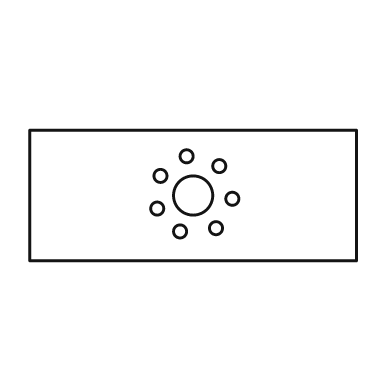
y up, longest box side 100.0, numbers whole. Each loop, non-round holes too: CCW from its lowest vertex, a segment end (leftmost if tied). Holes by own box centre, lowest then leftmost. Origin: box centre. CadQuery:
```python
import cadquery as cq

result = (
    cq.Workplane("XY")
    .moveTo(-50.0, -20.0)
    .lineTo(50.0, -20.0)
    .lineTo(50.0, 20.0)
    .lineTo(-50.0, 20.0)
    .close()
    .moveTo(-4.0, -11.0)
    .circle(2.0)
    .moveTo(7.0, -10.0)
    .circle(2.0)
    .moveTo(-11.0, -4.0)
    .circle(2.0)
    .moveTo(12.0, -1.0)
    .circle(2.0)
    .moveTo(0.0, 0.0)
    .circle(6.0)
    .moveTo(-10.0, 6.0)
    .circle(2.0)
    .moveTo(8.0, 9.0)
    .circle(2.0)
    .moveTo(-2.0, 12.0)
    .circle(2.0)
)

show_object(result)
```